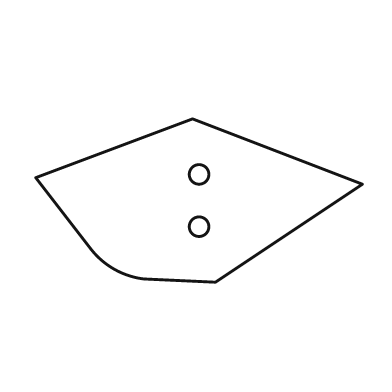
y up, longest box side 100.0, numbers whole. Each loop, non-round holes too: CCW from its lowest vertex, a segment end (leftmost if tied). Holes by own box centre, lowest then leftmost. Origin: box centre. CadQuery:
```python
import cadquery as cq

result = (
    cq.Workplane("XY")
    .moveTo(5.0, -25.0)
    .lineTo(50.0, 5.0)
    .lineTo(-2.0, 25.0)
    .lineTo(-50.0, 7.0)
    .lineTo(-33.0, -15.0)
    .threePointArc((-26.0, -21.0), (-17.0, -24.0))
    .close()
    .moveTo(0.0, -8.0)
    .circle(3.0)
    .moveTo(0.0, 8.0)
    .circle(3.0)
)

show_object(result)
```